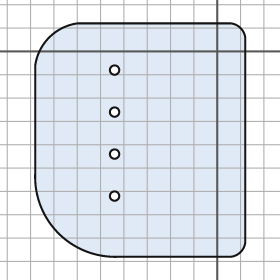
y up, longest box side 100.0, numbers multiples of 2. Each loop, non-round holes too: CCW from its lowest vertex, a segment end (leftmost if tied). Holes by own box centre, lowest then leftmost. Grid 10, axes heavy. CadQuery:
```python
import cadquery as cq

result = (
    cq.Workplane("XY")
    .moveTo(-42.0, -88.0)
    .lineTo(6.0, -88.0)
    .threePointArc((10.0, -86.0), (12.0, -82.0))
    .lineTo(12.0, 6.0)
    .threePointArc((10.0, 10.0), (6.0, 12.0))
    .lineTo(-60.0, 12.0)
    .threePointArc((-72.0, 6.0), (-78.0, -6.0))
    .lineTo(-78.0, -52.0)
    .threePointArc((-68.0, -78.0), (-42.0, -88.0))
    .close()
    .moveTo(-44.0, -62.0)
    .circle(2.0)
    .moveTo(-44.0, -44.0)
    .circle(2.0)
    .moveTo(-44.0, -26.0)
    .circle(2.0)
    .moveTo(-44.0, -8.0)
    .circle(2.0)
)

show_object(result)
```